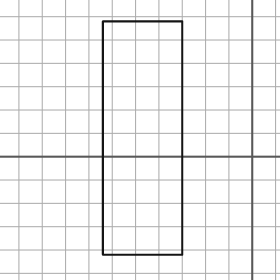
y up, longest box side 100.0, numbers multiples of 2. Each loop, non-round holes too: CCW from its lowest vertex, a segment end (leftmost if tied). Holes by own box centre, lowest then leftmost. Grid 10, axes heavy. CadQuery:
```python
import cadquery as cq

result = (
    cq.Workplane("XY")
    .moveTo(-64.0, -42.0)
    .lineTo(-30.0, -42.0)
    .lineTo(-30.0, 58.0)
    .lineTo(-64.0, 58.0)
    .close()
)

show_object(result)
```